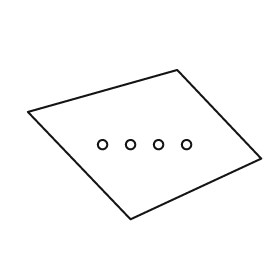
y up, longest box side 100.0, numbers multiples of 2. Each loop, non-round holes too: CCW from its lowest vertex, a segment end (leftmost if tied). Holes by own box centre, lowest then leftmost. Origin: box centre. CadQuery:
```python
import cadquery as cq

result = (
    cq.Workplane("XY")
    .moveTo(-6.0, -32.0)
    .lineTo(50.0, -6.0)
    .lineTo(14.0, 32.0)
    .lineTo(-50.0, 14.0)
    .close()
    .moveTo(-18.0, 0.0)
    .circle(2.0)
    .moveTo(-6.0, 0.0)
    .circle(2.0)
    .moveTo(6.0, 0.0)
    .circle(2.0)
    .moveTo(18.0, 0.0)
    .circle(2.0)
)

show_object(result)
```